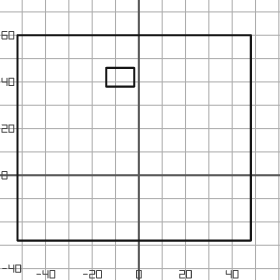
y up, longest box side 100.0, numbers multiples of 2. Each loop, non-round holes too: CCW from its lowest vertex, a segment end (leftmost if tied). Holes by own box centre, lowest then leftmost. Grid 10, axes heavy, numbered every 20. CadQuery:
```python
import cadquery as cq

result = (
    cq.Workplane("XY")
    .moveTo(-52.0, -28.0)
    .lineTo(48.0, -28.0)
    .lineTo(48.0, 60.0)
    .lineTo(-52.0, 60.0)
    .close()
    .moveTo(-14.0, 38.0)
    .lineTo(-2.0, 38.0)
    .lineTo(-2.0, 46.0)
    .lineTo(-14.0, 46.0)
    .close()
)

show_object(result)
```